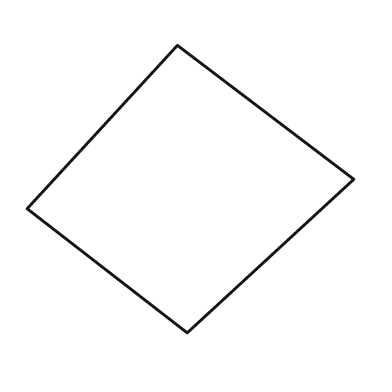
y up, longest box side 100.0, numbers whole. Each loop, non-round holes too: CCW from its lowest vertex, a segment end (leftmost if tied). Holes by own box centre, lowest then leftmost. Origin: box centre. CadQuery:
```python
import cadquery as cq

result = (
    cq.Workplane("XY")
    .moveTo(-1.0, -44.0)
    .lineTo(50.0, 3.0)
    .lineTo(-4.0, 44.0)
    .lineTo(-50.0, -6.0)
    .close()
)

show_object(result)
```